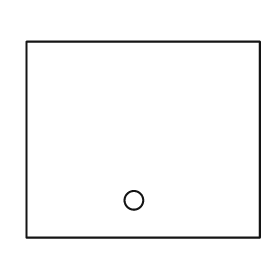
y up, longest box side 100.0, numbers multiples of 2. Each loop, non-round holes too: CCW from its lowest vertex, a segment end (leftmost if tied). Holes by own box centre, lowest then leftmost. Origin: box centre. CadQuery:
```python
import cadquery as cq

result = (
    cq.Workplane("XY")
    .moveTo(-50.0, -42.0)
    .lineTo(50.0, -42.0)
    .lineTo(50.0, 42.0)
    .lineTo(-50.0, 42.0)
    .close()
    .moveTo(-4.0, -26.0)
    .circle(4.0)
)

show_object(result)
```